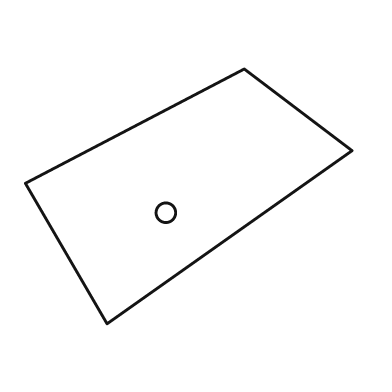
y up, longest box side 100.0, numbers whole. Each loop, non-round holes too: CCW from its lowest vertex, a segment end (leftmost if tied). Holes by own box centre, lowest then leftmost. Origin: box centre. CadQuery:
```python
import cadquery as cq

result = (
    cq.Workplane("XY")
    .moveTo(-25.0, -39.0)
    .lineTo(50.0, 14.0)
    .lineTo(17.0, 39.0)
    .lineTo(-50.0, 4.0)
    .close()
    .moveTo(-7.0, -5.0)
    .circle(3.0)
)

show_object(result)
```